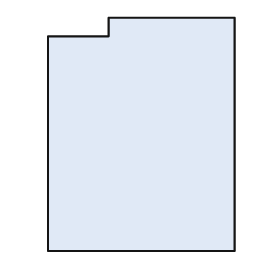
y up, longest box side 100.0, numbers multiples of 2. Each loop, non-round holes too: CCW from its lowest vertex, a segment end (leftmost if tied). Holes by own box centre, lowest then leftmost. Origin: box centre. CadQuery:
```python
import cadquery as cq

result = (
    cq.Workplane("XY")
    .moveTo(-40.0, -50.0)
    .lineTo(40.0, -50.0)
    .lineTo(40.0, 50.0)
    .lineTo(-14.0, 50.0)
    .lineTo(-14.0, 42.0)
    .lineTo(-40.0, 42.0)
    .close()
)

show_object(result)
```